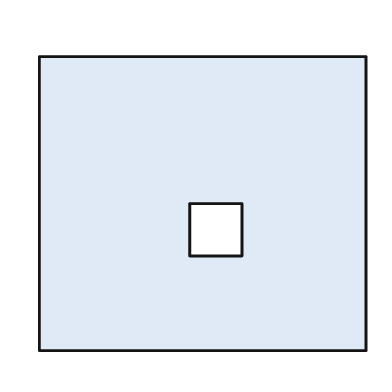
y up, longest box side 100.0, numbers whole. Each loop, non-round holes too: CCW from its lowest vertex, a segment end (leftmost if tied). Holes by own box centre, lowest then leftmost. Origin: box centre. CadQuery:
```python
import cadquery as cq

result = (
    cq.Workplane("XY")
    .moveTo(-50.0, -45.0)
    .lineTo(50.0, -45.0)
    .lineTo(50.0, 45.0)
    .lineTo(-50.0, 45.0)
    .close()
    .moveTo(-4.0, -16.0)
    .lineTo(12.0, -16.0)
    .lineTo(12.0, 0.0)
    .lineTo(-4.0, 0.0)
    .close()
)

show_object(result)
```